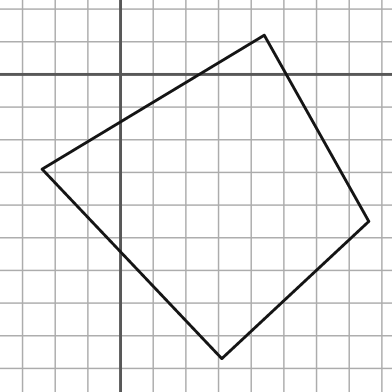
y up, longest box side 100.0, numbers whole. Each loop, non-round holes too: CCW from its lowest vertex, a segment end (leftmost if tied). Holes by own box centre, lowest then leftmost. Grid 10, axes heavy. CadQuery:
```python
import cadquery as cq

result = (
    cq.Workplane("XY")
    .moveTo(31.0, -87.0)
    .lineTo(76.0, -45.0)
    .lineTo(44.0, 12.0)
    .lineTo(-24.0, -29.0)
    .close()
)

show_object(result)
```